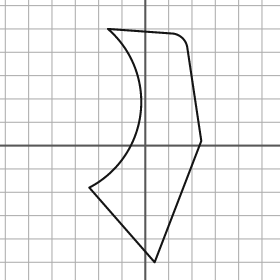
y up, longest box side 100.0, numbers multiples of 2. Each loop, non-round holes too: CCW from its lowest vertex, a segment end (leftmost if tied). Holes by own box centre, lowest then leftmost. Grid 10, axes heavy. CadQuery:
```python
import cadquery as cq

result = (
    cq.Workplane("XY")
    .moveTo(4.0, -50.0)
    .lineTo(24.0, 2.0)
    .lineTo(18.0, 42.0)
    .threePointArc((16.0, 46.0), (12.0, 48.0))
    .lineTo(-16.0, 50.0)
    .threePointArc((-2.0, 14.0), (-24.0, -18.0))
    .close()
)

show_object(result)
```